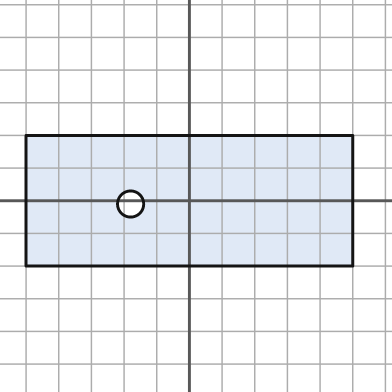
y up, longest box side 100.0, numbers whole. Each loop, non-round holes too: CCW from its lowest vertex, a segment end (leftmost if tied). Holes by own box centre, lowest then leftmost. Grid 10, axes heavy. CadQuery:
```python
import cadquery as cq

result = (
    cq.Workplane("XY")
    .moveTo(-50.0, -20.0)
    .lineTo(50.0, -20.0)
    .lineTo(50.0, 20.0)
    .lineTo(-50.0, 20.0)
    .close()
    .moveTo(-18.0, -1.0)
    .circle(4.0)
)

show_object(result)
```